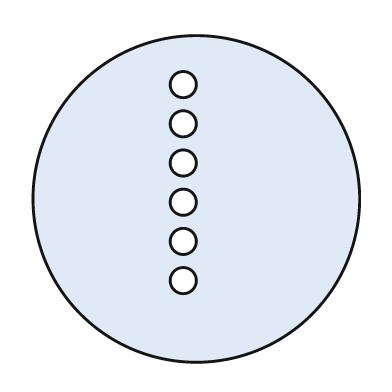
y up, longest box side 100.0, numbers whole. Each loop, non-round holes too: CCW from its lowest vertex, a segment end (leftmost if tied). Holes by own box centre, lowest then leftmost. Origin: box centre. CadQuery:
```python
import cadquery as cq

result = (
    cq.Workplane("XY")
    .moveTo(0.0, 0.0)
    .circle(50.0)
    .moveTo(-4.0, -25.0)
    .circle(4.0)
    .moveTo(-4.0, -13.0)
    .circle(4.0)
    .moveTo(-4.0, -1.0)
    .circle(4.0)
    .moveTo(-4.0, 11.0)
    .circle(4.0)
    .moveTo(-4.0, 23.0)
    .circle(4.0)
    .moveTo(-4.0, 35.0)
    .circle(4.0)
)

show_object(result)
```